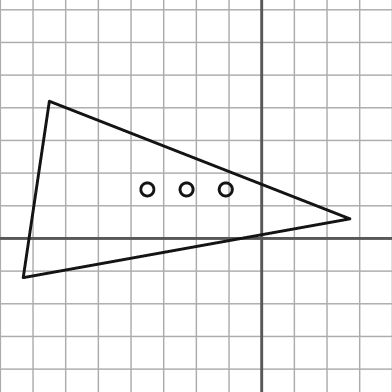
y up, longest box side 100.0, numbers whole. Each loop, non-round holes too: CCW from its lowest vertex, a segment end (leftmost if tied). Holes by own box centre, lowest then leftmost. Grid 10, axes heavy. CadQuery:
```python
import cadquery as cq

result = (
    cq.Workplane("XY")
    .moveTo(-73.0, -12.0)
    .lineTo(27.0, 6.0)
    .lineTo(-65.0, 42.0)
    .close()
    .moveTo(-35.0, 15.0)
    .circle(2.0)
    .moveTo(-23.0, 15.0)
    .circle(2.0)
    .moveTo(-11.0, 15.0)
    .circle(2.0)
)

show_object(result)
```